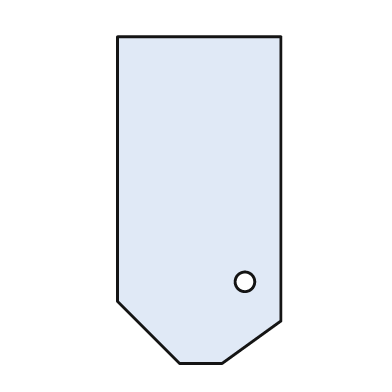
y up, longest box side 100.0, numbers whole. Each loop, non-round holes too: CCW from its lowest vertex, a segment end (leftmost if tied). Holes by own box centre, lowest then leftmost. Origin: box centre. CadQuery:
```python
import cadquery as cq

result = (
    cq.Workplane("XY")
    .moveTo(-6.0, -50.0)
    .lineTo(7.0, -50.0)
    .lineTo(25.0, -37.0)
    .lineTo(25.0, 50.0)
    .lineTo(-25.0, 50.0)
    .lineTo(-25.0, -31.0)
    .close()
    .moveTo(14.0, -25.0)
    .circle(3.0)
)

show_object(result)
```